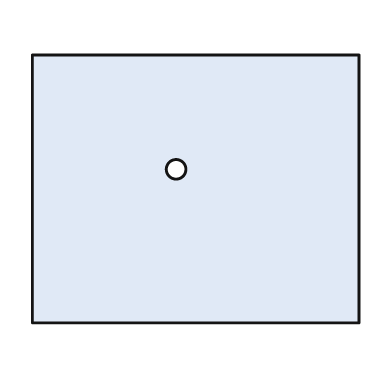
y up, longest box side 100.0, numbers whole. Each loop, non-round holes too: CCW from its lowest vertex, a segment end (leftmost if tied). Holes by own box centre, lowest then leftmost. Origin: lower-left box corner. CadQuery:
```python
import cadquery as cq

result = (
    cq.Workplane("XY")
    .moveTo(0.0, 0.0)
    .lineTo(100.0, 0.0)
    .lineTo(100.0, 82.0)
    .lineTo(0.0, 82.0)
    .close()
    .moveTo(44.0, 47.0)
    .circle(3.0)
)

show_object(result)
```